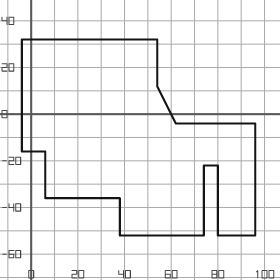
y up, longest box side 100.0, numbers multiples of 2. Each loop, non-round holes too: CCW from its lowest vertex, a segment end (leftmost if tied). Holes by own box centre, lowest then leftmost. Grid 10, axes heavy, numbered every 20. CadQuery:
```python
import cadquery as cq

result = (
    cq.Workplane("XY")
    .moveTo(38.0, -52.0)
    .lineTo(74.0, -52.0)
    .lineTo(74.0, -22.0)
    .lineTo(80.0, -22.0)
    .lineTo(80.0, -52.0)
    .lineTo(96.0, -52.0)
    .lineTo(96.0, -4.0)
    .lineTo(62.0, -4.0)
    .lineTo(54.0, 12.0)
    .lineTo(54.0, 32.0)
    .lineTo(-4.0, 32.0)
    .lineTo(-4.0, -16.0)
    .lineTo(6.0, -16.0)
    .lineTo(6.0, -36.0)
    .lineTo(38.0, -36.0)
    .close()
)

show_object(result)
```